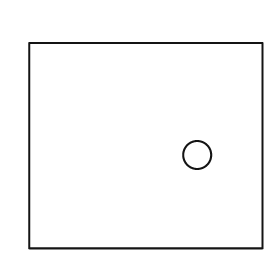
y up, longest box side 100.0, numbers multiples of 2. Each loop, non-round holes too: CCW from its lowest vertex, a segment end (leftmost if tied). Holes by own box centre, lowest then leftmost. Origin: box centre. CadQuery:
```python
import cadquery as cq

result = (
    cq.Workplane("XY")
    .moveTo(-50.0, -44.0)
    .lineTo(50.0, -44.0)
    .lineTo(50.0, 44.0)
    .lineTo(-50.0, 44.0)
    .close()
    .moveTo(22.0, -4.0)
    .circle(6.0)
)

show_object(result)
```